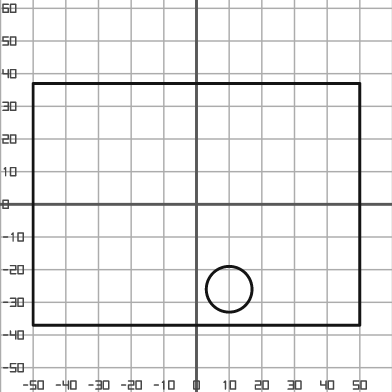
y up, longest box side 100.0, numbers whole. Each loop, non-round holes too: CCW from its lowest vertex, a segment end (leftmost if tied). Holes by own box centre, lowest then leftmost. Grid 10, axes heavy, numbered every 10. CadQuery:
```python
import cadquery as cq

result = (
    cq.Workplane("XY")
    .moveTo(-50.0, -37.0)
    .lineTo(50.0, -37.0)
    .lineTo(50.0, 37.0)
    .lineTo(-50.0, 37.0)
    .close()
    .moveTo(10.0, -26.0)
    .circle(7.0)
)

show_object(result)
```